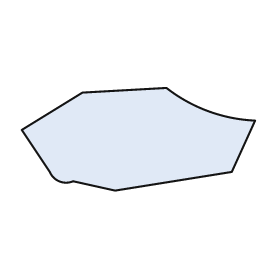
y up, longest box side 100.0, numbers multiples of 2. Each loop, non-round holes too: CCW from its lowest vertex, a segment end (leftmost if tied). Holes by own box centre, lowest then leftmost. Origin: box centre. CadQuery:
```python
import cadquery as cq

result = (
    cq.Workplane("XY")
    .moveTo(-10.0, -22.0)
    .lineTo(40.0, -14.0)
    .lineTo(50.0, 8.0)
    .threePointArc((30.0, 12.0), (12.0, 22.0))
    .lineTo(-24.0, 20.0)
    .lineTo(-50.0, 4.0)
    .lineTo(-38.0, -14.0)
    .threePointArc((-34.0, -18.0), (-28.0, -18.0))
    .close()
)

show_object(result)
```